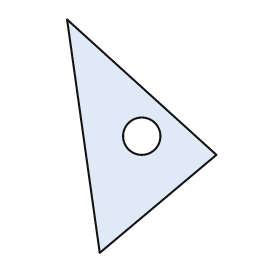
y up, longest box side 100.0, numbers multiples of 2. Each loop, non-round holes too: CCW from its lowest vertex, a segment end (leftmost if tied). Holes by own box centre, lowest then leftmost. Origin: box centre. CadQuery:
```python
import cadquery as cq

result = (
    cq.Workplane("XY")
    .moveTo(-18.0, -50.0)
    .lineTo(32.0, -8.0)
    .lineTo(-32.0, 50.0)
    .close()
    .moveTo(0.0, 0.0)
    .circle(8.0)
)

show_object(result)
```